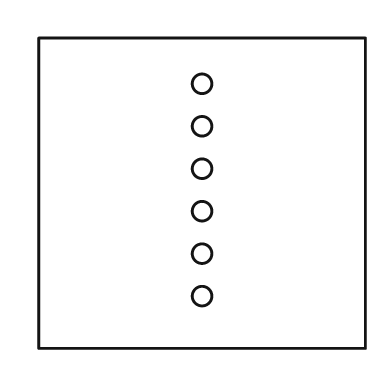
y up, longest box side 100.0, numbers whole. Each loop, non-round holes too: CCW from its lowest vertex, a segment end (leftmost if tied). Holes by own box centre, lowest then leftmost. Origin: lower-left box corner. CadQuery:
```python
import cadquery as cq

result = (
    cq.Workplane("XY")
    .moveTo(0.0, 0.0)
    .lineTo(100.0, 0.0)
    .lineTo(100.0, 95.0)
    .lineTo(0.0, 95.0)
    .close()
    .moveTo(50.0, 16.0)
    .circle(3.0)
    .moveTo(50.0, 29.0)
    .circle(3.0)
    .moveTo(50.0, 42.0)
    .circle(3.0)
    .moveTo(50.0, 55.0)
    .circle(3.0)
    .moveTo(50.0, 68.0)
    .circle(3.0)
    .moveTo(50.0, 81.0)
    .circle(3.0)
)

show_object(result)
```